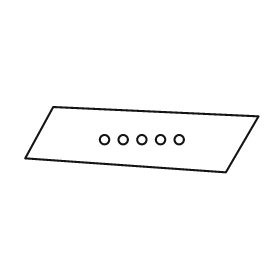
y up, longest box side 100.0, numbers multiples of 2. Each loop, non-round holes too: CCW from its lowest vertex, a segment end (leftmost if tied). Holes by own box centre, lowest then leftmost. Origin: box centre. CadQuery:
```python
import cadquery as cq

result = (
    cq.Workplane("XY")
    .moveTo(36.0, -14.0)
    .lineTo(50.0, 10.0)
    .lineTo(-38.0, 14.0)
    .lineTo(-50.0, -8.0)
    .close()
    .moveTo(-16.0, 0.0)
    .circle(2.0)
    .moveTo(-8.0, 0.0)
    .circle(2.0)
    .moveTo(0.0, 0.0)
    .circle(2.0)
    .moveTo(8.0, 0.0)
    .circle(2.0)
    .moveTo(16.0, 0.0)
    .circle(2.0)
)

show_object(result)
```